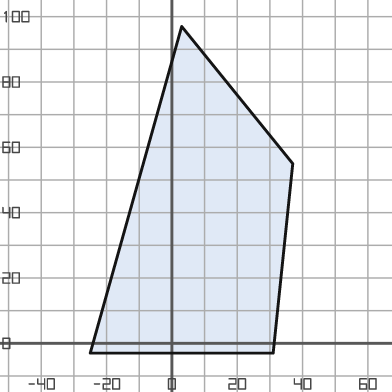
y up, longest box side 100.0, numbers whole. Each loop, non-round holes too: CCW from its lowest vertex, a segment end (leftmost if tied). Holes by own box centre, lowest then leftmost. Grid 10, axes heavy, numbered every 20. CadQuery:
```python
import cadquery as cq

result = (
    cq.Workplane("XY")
    .moveTo(-25.0, -3.0)
    .lineTo(31.0, -3.0)
    .lineTo(37.0, 55.0)
    .lineTo(3.0, 97.0)
    .close()
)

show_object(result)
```